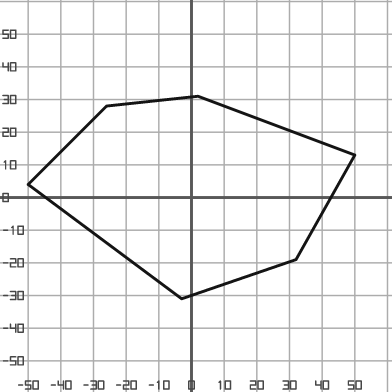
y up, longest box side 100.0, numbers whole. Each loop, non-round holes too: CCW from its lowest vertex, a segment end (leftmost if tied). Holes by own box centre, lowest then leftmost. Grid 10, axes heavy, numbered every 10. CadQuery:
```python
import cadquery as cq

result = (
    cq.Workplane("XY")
    .moveTo(-3.0, -31.0)
    .lineTo(32.0, -19.0)
    .lineTo(50.0, 13.0)
    .lineTo(2.0, 31.0)
    .lineTo(-26.0, 28.0)
    .lineTo(-50.0, 4.0)
    .close()
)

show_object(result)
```